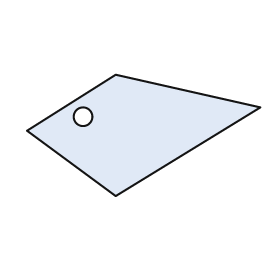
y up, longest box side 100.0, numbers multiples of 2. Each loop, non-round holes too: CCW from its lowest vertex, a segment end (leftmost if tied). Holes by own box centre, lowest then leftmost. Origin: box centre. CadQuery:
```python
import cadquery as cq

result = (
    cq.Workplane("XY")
    .moveTo(-12.0, -26.0)
    .lineTo(50.0, 12.0)
    .lineTo(-12.0, 26.0)
    .lineTo(-50.0, 2.0)
    .close()
    .moveTo(-26.0, 8.0)
    .circle(4.0)
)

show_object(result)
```